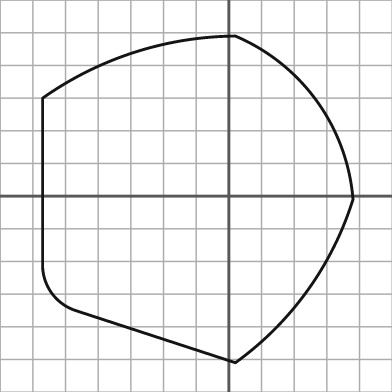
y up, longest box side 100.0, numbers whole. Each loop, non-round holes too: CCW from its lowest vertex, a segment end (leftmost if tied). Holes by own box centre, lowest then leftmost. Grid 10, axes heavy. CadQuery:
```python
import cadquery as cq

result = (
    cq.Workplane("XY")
    .moveTo(2.0, -51.0)
    .threePointArc((24.0, -29.0), (38.0, -1.0))
    .threePointArc((27.0, 29.0), (2.0, 49.0))
    .threePointArc((-29.0, 44.0), (-57.0, 30.0))
    .lineTo(-57.0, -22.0)
    .threePointArc((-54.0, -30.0), (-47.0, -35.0))
    .close()
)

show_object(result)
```